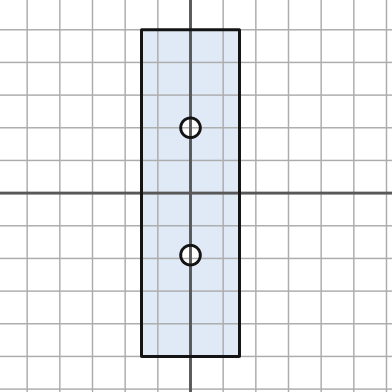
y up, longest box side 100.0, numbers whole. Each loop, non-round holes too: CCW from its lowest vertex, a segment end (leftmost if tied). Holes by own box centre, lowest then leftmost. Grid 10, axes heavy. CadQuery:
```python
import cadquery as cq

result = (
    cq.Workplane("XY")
    .moveTo(-15.0, -50.0)
    .lineTo(15.0, -50.0)
    .lineTo(15.0, 50.0)
    .lineTo(-15.0, 50.0)
    .close()
    .moveTo(0.0, -19.0)
    .circle(3.0)
    .moveTo(0.0, 20.0)
    .circle(3.0)
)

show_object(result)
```